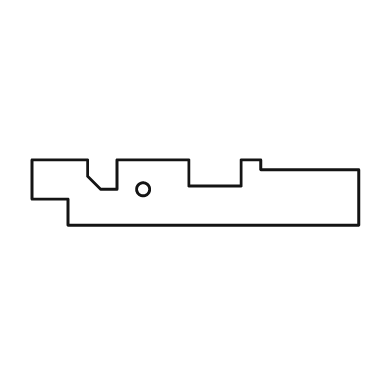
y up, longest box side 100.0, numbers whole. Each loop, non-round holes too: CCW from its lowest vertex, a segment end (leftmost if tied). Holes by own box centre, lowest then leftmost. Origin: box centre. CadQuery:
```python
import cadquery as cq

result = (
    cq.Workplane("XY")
    .moveTo(-39.0, -10.0)
    .lineTo(50.0, -10.0)
    .lineTo(50.0, 7.0)
    .lineTo(20.0, 7.0)
    .lineTo(20.0, 10.0)
    .lineTo(14.0, 10.0)
    .lineTo(14.0, 2.0)
    .lineTo(-2.0, 2.0)
    .lineTo(-2.0, 10.0)
    .lineTo(-24.0, 10.0)
    .lineTo(-24.0, 1.0)
    .lineTo(-29.0, 1.0)
    .lineTo(-33.0, 5.0)
    .lineTo(-33.0, 10.0)
    .lineTo(-50.0, 10.0)
    .lineTo(-50.0, -2.0)
    .lineTo(-39.0, -2.0)
    .close()
    .moveTo(-16.0, 1.0)
    .circle(2.0)
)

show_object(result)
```